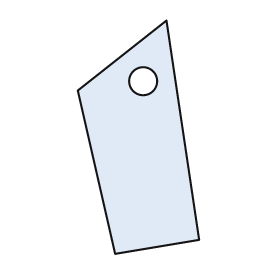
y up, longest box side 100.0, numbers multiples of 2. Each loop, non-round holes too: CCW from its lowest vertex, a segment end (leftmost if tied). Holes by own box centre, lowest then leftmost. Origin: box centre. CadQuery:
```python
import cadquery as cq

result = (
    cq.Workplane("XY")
    .moveTo(-10.0, -50.0)
    .lineTo(26.0, -44.0)
    .lineTo(12.0, 50.0)
    .lineTo(-26.0, 20.0)
    .close()
    .moveTo(2.0, 24.0)
    .circle(6.0)
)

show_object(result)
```